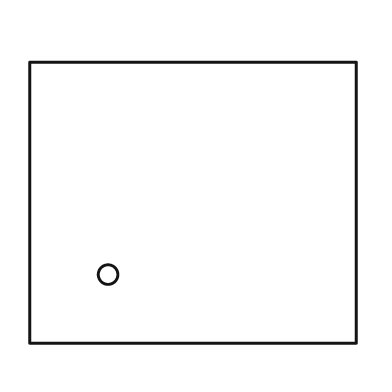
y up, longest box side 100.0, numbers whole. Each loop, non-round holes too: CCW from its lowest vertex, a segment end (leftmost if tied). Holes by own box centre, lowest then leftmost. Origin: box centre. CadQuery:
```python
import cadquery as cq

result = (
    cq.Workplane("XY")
    .moveTo(-50.0, -43.0)
    .lineTo(50.0, -43.0)
    .lineTo(50.0, 43.0)
    .lineTo(-50.0, 43.0)
    .close()
    .moveTo(-26.0, -22.0)
    .circle(3.0)
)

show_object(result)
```